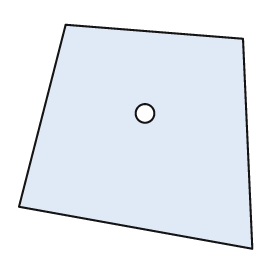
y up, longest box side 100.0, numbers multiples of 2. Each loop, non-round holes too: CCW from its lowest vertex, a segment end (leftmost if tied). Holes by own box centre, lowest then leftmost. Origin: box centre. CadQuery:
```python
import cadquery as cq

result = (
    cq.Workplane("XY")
    .moveTo(50.0, -48.0)
    .lineTo(46.0, 42.0)
    .lineTo(-30.0, 48.0)
    .lineTo(-50.0, -30.0)
    .close()
    .moveTo(4.0, 10.0)
    .circle(4.0)
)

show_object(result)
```